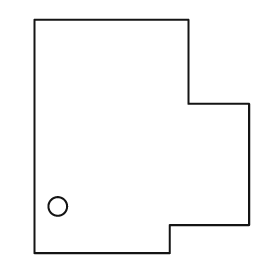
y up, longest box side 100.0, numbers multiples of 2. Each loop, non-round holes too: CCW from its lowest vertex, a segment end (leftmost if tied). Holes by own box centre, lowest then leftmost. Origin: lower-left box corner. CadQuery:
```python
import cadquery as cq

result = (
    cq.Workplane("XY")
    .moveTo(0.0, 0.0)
    .lineTo(58.0, 0.0)
    .lineTo(58.0, 12.0)
    .lineTo(92.0, 12.0)
    .lineTo(92.0, 64.0)
    .lineTo(66.0, 64.0)
    .lineTo(66.0, 100.0)
    .lineTo(0.0, 100.0)
    .close()
    .moveTo(10.0, 20.0)
    .circle(4.0)
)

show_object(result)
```